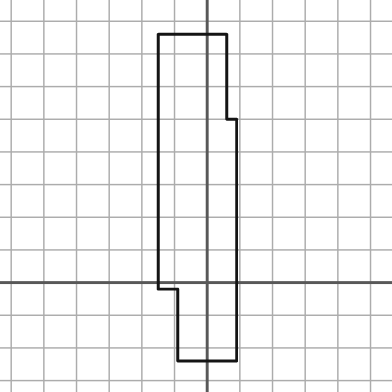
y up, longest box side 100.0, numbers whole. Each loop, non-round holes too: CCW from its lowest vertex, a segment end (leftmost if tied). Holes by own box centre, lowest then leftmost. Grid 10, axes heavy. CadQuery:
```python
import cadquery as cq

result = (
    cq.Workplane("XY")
    .moveTo(-9.0, -24.0)
    .lineTo(9.0, -24.0)
    .lineTo(9.0, 50.0)
    .lineTo(6.0, 50.0)
    .lineTo(6.0, 76.0)
    .lineTo(-15.0, 76.0)
    .lineTo(-15.0, -2.0)
    .lineTo(-9.0, -2.0)
    .close()
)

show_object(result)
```